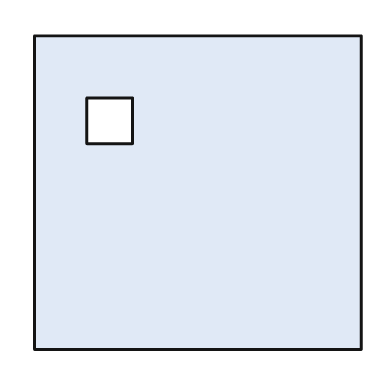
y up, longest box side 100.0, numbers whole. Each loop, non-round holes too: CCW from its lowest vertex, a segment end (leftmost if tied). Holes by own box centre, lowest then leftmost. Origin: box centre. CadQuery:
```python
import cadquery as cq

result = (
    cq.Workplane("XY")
    .moveTo(-50.0, -48.0)
    .lineTo(50.0, -48.0)
    .lineTo(50.0, 48.0)
    .lineTo(-50.0, 48.0)
    .close()
    .moveTo(-34.0, 15.0)
    .lineTo(-20.0, 15.0)
    .lineTo(-20.0, 29.0)
    .lineTo(-34.0, 29.0)
    .close()
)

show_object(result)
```